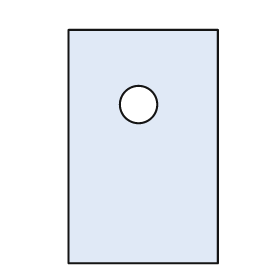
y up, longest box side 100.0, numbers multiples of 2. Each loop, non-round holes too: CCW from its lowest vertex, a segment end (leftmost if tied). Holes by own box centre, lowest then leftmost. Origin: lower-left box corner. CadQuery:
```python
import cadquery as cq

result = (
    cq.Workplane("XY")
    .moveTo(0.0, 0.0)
    .lineTo(64.0, 0.0)
    .lineTo(64.0, 100.0)
    .lineTo(0.0, 100.0)
    .close()
    .moveTo(30.0, 68.0)
    .circle(8.0)
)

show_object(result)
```